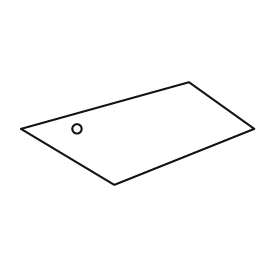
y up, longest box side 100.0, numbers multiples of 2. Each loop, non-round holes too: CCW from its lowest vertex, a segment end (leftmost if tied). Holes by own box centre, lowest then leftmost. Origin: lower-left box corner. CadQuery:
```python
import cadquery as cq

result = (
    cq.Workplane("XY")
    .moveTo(40.0, 0.0)
    .lineTo(100.0, 24.0)
    .lineTo(72.0, 44.0)
    .lineTo(0.0, 24.0)
    .close()
    .moveTo(24.0, 24.0)
    .circle(2.0)
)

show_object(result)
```